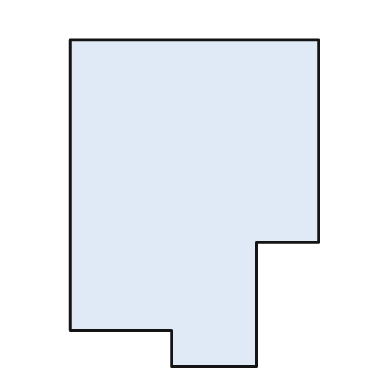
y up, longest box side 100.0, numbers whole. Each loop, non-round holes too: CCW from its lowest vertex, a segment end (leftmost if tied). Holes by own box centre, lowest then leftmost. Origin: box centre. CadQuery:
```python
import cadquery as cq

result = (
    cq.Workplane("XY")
    .moveTo(-7.0, -50.0)
    .lineTo(19.0, -50.0)
    .lineTo(19.0, -12.0)
    .lineTo(38.0, -12.0)
    .lineTo(38.0, 50.0)
    .lineTo(-38.0, 50.0)
    .lineTo(-38.0, -39.0)
    .lineTo(-7.0, -39.0)
    .close()
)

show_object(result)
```